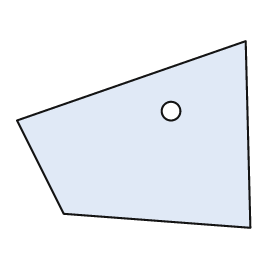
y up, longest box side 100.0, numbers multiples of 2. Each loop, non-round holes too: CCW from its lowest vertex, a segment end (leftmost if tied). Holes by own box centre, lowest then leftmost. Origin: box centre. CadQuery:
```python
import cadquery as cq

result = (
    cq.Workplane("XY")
    .moveTo(50.0, -40.0)
    .lineTo(48.0, 40.0)
    .lineTo(-50.0, 6.0)
    .lineTo(-30.0, -34.0)
    .close()
    .moveTo(16.0, 10.0)
    .circle(4.0)
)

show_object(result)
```